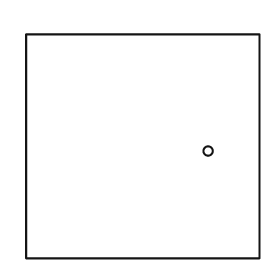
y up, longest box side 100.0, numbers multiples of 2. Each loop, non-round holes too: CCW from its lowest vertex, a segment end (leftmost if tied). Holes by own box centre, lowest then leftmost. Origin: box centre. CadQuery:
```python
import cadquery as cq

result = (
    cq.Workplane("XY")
    .moveTo(-50.0, -48.0)
    .lineTo(50.0, -48.0)
    .lineTo(50.0, 48.0)
    .lineTo(-50.0, 48.0)
    .close()
    .moveTo(28.0, -2.0)
    .circle(2.0)
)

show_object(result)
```